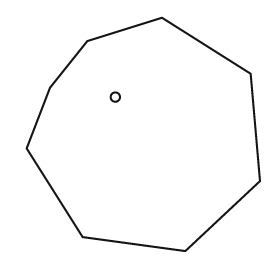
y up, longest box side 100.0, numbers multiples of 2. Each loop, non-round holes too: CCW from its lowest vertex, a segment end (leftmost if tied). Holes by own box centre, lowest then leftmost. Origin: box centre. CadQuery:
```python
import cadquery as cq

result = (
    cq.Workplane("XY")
    .moveTo(18.0, -50.0)
    .lineTo(50.0, -20.0)
    .lineTo(46.0, 26.0)
    .lineTo(8.0, 50.0)
    .lineTo(-24.0, 40.0)
    .lineTo(-40.0, 20.0)
    .lineTo(-50.0, -6.0)
    .lineTo(-26.0, -44.0)
    .close()
    .moveTo(-12.0, 16.0)
    .circle(2.0)
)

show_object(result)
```